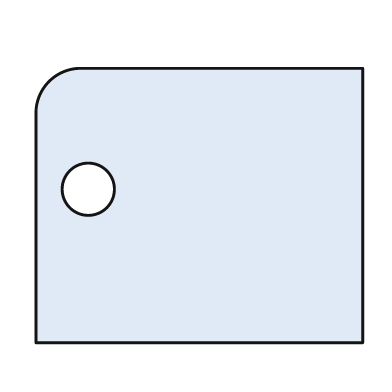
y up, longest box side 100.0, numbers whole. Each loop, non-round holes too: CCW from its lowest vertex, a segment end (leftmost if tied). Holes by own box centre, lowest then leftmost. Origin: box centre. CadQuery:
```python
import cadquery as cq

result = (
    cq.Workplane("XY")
    .moveTo(-50.0, -42.0)
    .lineTo(50.0, -42.0)
    .lineTo(50.0, 42.0)
    .lineTo(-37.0, 42.0)
    .threePointArc((-46.0, 38.0), (-50.0, 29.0))
    .close()
    .moveTo(-34.0, 5.0)
    .circle(8.0)
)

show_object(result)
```